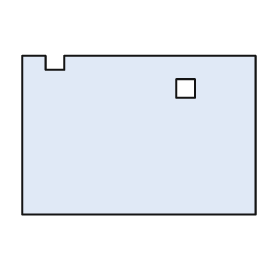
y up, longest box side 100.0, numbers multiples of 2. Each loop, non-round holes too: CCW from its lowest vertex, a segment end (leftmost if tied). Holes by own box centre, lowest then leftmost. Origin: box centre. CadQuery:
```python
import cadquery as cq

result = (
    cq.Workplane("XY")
    .moveTo(-50.0, -34.0)
    .lineTo(50.0, -34.0)
    .lineTo(50.0, 34.0)
    .lineTo(-32.0, 34.0)
    .lineTo(-32.0, 28.0)
    .lineTo(-40.0, 28.0)
    .lineTo(-40.0, 34.0)
    .lineTo(-50.0, 34.0)
    .close()
    .moveTo(16.0, 16.0)
    .lineTo(24.0, 16.0)
    .lineTo(24.0, 24.0)
    .lineTo(16.0, 24.0)
    .close()
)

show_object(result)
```